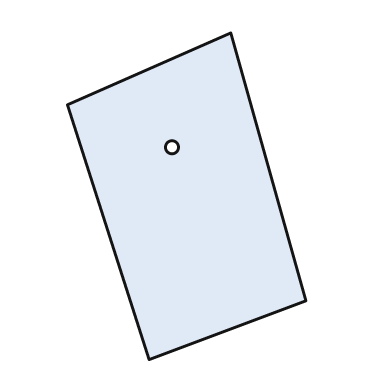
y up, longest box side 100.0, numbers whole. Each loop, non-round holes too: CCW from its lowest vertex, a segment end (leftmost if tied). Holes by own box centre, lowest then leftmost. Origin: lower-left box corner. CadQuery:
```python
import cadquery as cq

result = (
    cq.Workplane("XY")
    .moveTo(25.0, 0.0)
    .lineTo(73.0, 18.0)
    .lineTo(50.0, 100.0)
    .lineTo(0.0, 78.0)
    .close()
    .moveTo(32.0, 65.0)
    .circle(2.0)
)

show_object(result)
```